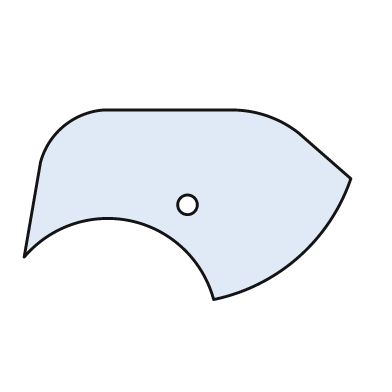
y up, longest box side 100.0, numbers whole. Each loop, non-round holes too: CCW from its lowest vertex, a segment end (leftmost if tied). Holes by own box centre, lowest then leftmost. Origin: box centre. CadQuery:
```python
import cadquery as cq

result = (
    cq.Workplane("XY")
    .moveTo(8.0, -29.0)
    .threePointArc((34.0, -16.0), (50.0, 8.0))
    .lineTo(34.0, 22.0)
    .threePointArc((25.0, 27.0), (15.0, 29.0))
    .lineTo(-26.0, 29.0)
    .threePointArc((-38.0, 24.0), (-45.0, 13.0))
    .lineTo(-50.0, -16.0)
    .threePointArc((-17.0, -5.0), (8.0, -29.0))
    .close()
    .moveTo(0.0, 0.0)
    .circle(3.0)
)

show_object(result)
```